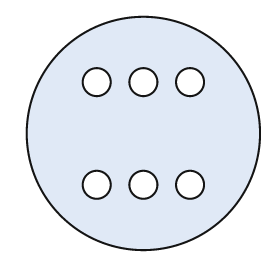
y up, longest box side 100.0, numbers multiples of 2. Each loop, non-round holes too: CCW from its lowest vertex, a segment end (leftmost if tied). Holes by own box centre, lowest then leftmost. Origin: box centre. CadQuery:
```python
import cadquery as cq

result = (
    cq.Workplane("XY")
    .moveTo(0.0, 0.0)
    .circle(50.0)
    .moveTo(-20.0, -22.0)
    .circle(6.0)
    .moveTo(0.0, -22.0)
    .circle(6.0)
    .moveTo(20.0, -22.0)
    .circle(6.0)
    .moveTo(-20.0, 22.0)
    .circle(6.0)
    .moveTo(0.0, 22.0)
    .circle(6.0)
    .moveTo(20.0, 22.0)
    .circle(6.0)
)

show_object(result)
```